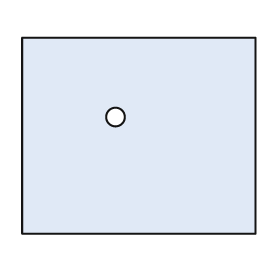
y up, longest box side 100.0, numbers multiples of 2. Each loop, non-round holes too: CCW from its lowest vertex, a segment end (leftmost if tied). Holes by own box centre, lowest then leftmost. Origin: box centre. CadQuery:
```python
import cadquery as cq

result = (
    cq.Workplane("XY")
    .moveTo(-50.0, -42.0)
    .lineTo(50.0, -42.0)
    .lineTo(50.0, 42.0)
    .lineTo(-50.0, 42.0)
    .close()
    .moveTo(-10.0, 8.0)
    .circle(4.0)
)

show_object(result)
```